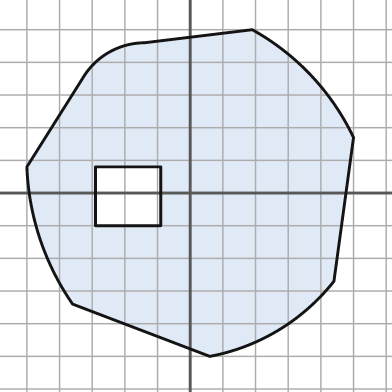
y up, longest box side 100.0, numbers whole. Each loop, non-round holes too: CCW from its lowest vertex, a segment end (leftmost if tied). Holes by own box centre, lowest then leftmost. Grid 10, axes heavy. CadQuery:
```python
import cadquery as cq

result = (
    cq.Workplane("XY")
    .moveTo(6.0, -50.0)
    .threePointArc((27.0, -42.0), (44.0, -27.0))
    .lineTo(50.0, 17.0)
    .threePointArc((37.0, 36.0), (19.0, 50.0))
    .lineTo(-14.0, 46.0)
    .threePointArc((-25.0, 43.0), (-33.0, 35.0))
    .lineTo(-50.0, 8.0)
    .threePointArc((-46.0, -14.0), (-36.0, -34.0))
    .close()
    .moveTo(-29.0, -10.0)
    .lineTo(-9.0, -10.0)
    .lineTo(-9.0, 8.0)
    .lineTo(-29.0, 8.0)
    .close()
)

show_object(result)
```